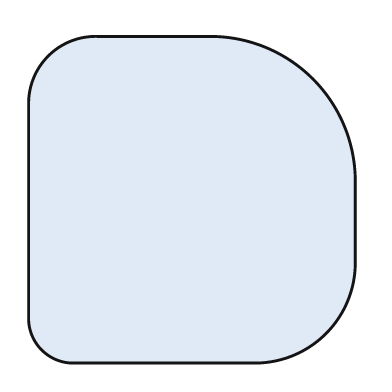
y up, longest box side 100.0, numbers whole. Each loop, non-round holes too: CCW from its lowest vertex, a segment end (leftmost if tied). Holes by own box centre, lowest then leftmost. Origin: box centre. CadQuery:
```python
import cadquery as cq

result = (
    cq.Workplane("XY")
    .moveTo(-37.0, -50.0)
    .lineTo(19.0, -50.0)
    .threePointArc((41.0, -41.0), (50.0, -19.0))
    .lineTo(50.0, 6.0)
    .threePointArc((37.0, 37.0), (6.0, 50.0))
    .lineTo(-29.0, 50.0)
    .threePointArc((-44.0, 44.0), (-50.0, 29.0))
    .lineTo(-50.0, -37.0)
    .threePointArc((-46.0, -46.0), (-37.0, -50.0))
    .close()
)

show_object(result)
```